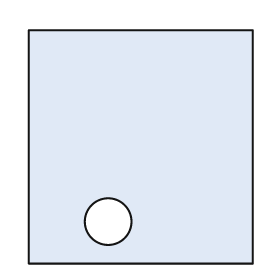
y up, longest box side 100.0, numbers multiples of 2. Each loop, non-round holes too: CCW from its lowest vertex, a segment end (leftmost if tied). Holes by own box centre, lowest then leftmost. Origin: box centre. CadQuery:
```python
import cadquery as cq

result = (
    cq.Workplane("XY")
    .moveTo(-48.0, -50.0)
    .lineTo(48.0, -50.0)
    .lineTo(48.0, 50.0)
    .lineTo(-48.0, 50.0)
    .close()
    .moveTo(-14.0, -32.0)
    .circle(10.0)
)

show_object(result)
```